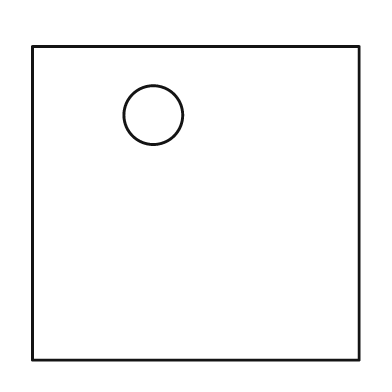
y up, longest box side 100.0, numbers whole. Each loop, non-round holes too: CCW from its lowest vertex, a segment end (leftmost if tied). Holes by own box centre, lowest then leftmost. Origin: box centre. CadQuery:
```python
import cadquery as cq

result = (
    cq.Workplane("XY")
    .moveTo(-50.0, -48.0)
    .lineTo(50.0, -48.0)
    .lineTo(50.0, 48.0)
    .lineTo(-50.0, 48.0)
    .close()
    .moveTo(-13.0, 27.0)
    .circle(9.0)
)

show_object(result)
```